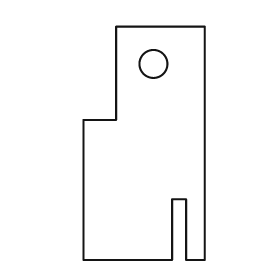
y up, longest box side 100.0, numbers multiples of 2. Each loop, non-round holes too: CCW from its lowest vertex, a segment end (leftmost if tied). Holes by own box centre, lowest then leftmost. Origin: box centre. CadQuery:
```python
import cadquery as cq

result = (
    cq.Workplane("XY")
    .moveTo(-26.0, -50.0)
    .lineTo(12.0, -50.0)
    .lineTo(12.0, -24.0)
    .lineTo(18.0, -24.0)
    .lineTo(18.0, -50.0)
    .lineTo(26.0, -50.0)
    .lineTo(26.0, 50.0)
    .lineTo(-12.0, 50.0)
    .lineTo(-12.0, 10.0)
    .lineTo(-26.0, 10.0)
    .close()
    .moveTo(4.0, 34.0)
    .circle(6.0)
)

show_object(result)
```